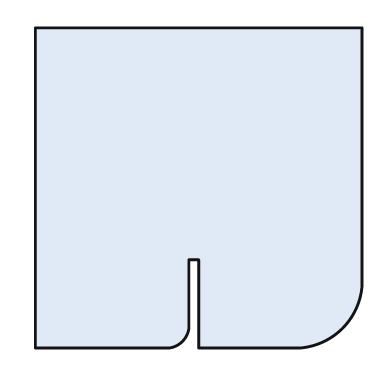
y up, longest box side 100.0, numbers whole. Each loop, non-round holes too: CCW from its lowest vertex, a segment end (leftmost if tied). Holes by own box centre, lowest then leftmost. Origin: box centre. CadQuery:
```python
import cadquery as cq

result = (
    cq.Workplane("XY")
    .moveTo(-50.0, -49.0)
    .lineTo(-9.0, -49.0)
    .threePointArc((-5.0, -47.0), (-3.0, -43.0))
    .lineTo(-3.0, -22.0)
    .lineTo(0.0, -22.0)
    .lineTo(0.0, -49.0)
    .lineTo(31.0, -49.0)
    .threePointArc((44.0, -43.0), (50.0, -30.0))
    .lineTo(50.0, 49.0)
    .lineTo(-50.0, 49.0)
    .close()
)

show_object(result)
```